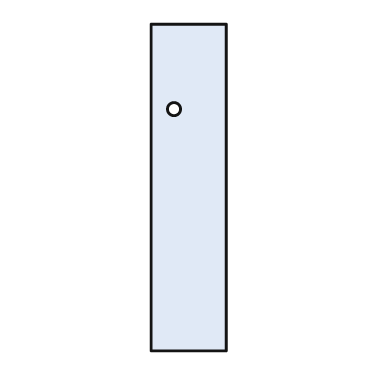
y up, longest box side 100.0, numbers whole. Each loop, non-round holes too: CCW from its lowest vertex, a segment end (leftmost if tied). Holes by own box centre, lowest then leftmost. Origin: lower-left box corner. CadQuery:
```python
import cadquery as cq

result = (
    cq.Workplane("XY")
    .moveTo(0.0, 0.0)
    .lineTo(23.0, 0.0)
    .lineTo(23.0, 100.0)
    .lineTo(0.0, 100.0)
    .close()
    .moveTo(7.0, 74.0)
    .circle(2.0)
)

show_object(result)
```